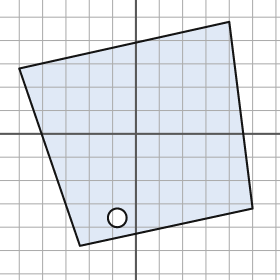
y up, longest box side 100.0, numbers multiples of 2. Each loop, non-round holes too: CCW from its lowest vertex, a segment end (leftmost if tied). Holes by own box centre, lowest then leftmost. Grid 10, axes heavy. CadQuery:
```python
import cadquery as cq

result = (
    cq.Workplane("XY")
    .moveTo(-24.0, -48.0)
    .lineTo(50.0, -32.0)
    .lineTo(40.0, 48.0)
    .lineTo(-50.0, 28.0)
    .close()
    .moveTo(-8.0, -36.0)
    .circle(4.0)
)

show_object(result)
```